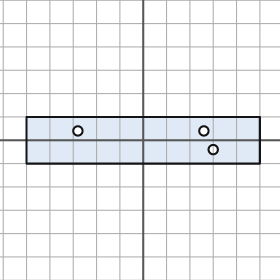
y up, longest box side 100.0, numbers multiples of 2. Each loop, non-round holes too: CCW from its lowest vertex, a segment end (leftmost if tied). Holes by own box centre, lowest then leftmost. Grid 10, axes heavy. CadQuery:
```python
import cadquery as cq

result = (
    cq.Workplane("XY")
    .moveTo(-50.0, -10.0)
    .lineTo(50.0, -10.0)
    .lineTo(50.0, 10.0)
    .lineTo(-50.0, 10.0)
    .close()
    .moveTo(30.0, -4.0)
    .circle(2.0)
    .moveTo(-28.0, 4.0)
    .circle(2.0)
    .moveTo(26.0, 4.0)
    .circle(2.0)
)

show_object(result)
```